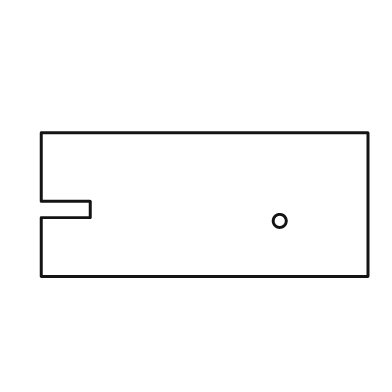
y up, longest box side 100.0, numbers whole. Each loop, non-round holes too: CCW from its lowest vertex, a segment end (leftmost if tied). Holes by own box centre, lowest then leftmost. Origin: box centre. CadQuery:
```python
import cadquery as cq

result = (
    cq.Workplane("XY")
    .moveTo(-50.0, -22.0)
    .lineTo(50.0, -22.0)
    .lineTo(50.0, 22.0)
    .lineTo(-50.0, 22.0)
    .lineTo(-50.0, 1.0)
    .lineTo(-35.0, 1.0)
    .lineTo(-35.0, -4.0)
    .lineTo(-50.0, -4.0)
    .close()
    .moveTo(23.0, -5.0)
    .circle(2.0)
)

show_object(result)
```